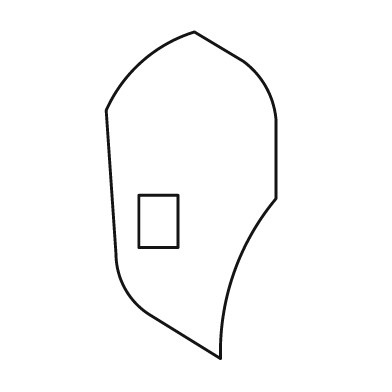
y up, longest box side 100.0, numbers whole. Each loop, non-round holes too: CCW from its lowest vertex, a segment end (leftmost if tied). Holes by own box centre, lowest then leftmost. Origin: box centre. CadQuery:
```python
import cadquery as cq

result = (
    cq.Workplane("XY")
    .moveTo(9.0, -50.0)
    .threePointArc((13.0, -24.0), (26.0, -1.0))
    .lineTo(26.0, 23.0)
    .threePointArc((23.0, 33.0), (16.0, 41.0))
    .lineTo(1.0, 50.0)
    .threePointArc((-15.0, 41.0), (-26.0, 26.0))
    .lineTo(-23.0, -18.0)
    .threePointArc((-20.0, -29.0), (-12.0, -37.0))
    .close()
    .moveTo(-16.0, -16.0)
    .lineTo(-4.0, -16.0)
    .lineTo(-4.0, 0.0)
    .lineTo(-16.0, 0.0)
    .close()
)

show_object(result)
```